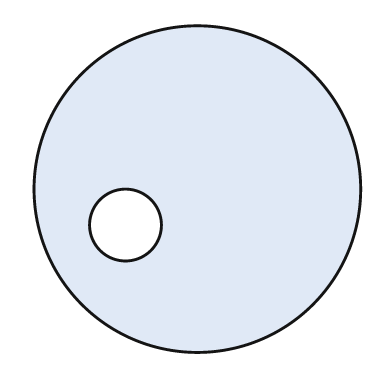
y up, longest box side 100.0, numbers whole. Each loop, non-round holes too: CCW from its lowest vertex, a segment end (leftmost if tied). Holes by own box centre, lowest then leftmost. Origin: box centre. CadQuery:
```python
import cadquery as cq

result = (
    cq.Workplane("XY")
    .moveTo(0.0, 0.0)
    .circle(50.0)
    .moveTo(-22.0, -11.0)
    .circle(11.0)
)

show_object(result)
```